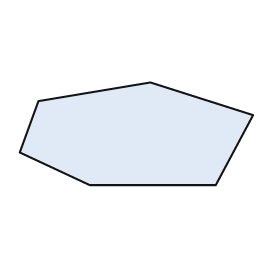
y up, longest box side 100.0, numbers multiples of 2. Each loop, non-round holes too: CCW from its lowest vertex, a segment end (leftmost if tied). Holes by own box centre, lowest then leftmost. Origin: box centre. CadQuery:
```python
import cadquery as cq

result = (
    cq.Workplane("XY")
    .moveTo(-20.0, -22.0)
    .lineTo(34.0, -22.0)
    .lineTo(50.0, 8.0)
    .lineTo(6.0, 22.0)
    .lineTo(-42.0, 14.0)
    .lineTo(-50.0, -8.0)
    .close()
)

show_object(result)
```